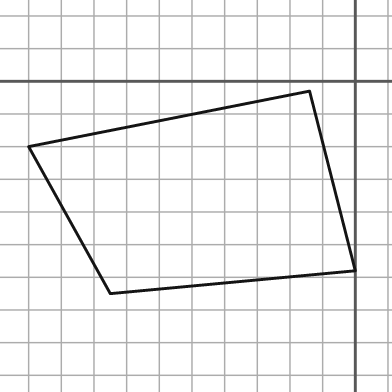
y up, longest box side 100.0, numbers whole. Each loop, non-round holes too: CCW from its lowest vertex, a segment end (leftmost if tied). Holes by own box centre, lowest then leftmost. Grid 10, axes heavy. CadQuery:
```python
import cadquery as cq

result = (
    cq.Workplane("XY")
    .moveTo(-75.0, -65.0)
    .lineTo(0.0, -58.0)
    .lineTo(-14.0, -3.0)
    .lineTo(-100.0, -20.0)
    .close()
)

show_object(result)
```